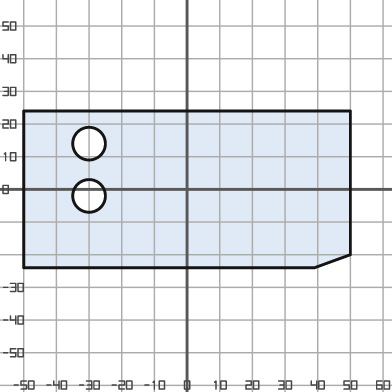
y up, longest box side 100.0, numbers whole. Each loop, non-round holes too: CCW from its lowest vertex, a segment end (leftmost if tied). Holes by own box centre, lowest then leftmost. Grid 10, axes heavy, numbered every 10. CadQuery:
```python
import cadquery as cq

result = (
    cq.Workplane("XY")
    .moveTo(-50.0, -24.0)
    .lineTo(39.0, -24.0)
    .lineTo(50.0, -20.0)
    .lineTo(50.0, 24.0)
    .lineTo(-50.0, 24.0)
    .close()
    .moveTo(-30.0, -2.0)
    .circle(5.0)
    .moveTo(-30.0, 14.0)
    .circle(5.0)
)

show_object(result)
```